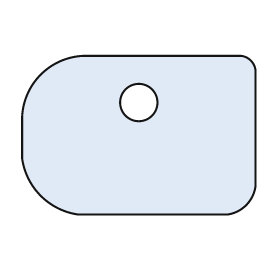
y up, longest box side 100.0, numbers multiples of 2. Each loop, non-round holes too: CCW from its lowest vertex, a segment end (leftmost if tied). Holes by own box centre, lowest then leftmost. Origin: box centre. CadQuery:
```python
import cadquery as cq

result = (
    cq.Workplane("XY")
    .moveTo(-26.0, -34.0)
    .lineTo(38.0, -34.0)
    .threePointArc((46.0, -30.0), (50.0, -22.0))
    .lineTo(50.0, 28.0)
    .threePointArc((48.0, 32.0), (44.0, 34.0))
    .lineTo(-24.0, 34.0)
    .threePointArc((-42.0, 26.0), (-50.0, 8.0))
    .lineTo(-50.0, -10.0)
    .threePointArc((-42.0, -26.0), (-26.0, -34.0))
    .close()
    .moveTo(0.0, 14.0)
    .circle(8.0)
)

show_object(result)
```